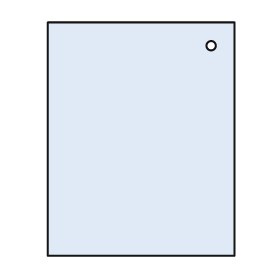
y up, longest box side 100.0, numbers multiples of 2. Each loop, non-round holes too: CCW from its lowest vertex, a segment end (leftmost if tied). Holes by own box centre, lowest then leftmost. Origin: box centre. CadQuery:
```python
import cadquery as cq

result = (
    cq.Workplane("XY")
    .moveTo(-40.0, -50.0)
    .lineTo(40.0, -50.0)
    .lineTo(40.0, 50.0)
    .lineTo(-40.0, 50.0)
    .close()
    .moveTo(30.0, 40.0)
    .circle(2.0)
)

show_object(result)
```